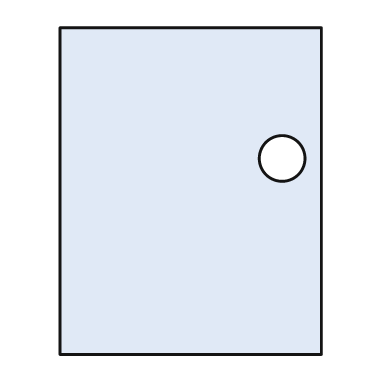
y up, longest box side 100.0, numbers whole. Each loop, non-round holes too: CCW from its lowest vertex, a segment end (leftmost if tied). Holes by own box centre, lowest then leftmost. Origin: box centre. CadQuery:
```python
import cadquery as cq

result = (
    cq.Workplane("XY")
    .moveTo(-40.0, -50.0)
    .lineTo(40.0, -50.0)
    .lineTo(40.0, 50.0)
    .lineTo(-40.0, 50.0)
    .close()
    .moveTo(28.0, 10.0)
    .circle(7.0)
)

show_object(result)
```